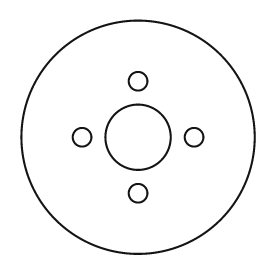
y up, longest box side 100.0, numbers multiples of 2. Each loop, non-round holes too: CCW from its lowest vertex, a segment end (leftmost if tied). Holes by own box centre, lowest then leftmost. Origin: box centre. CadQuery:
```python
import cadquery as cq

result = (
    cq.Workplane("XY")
    .moveTo(0.0, 0.0)
    .circle(50.0)
    .moveTo(0.0, -24.0)
    .circle(4.0)
    .moveTo(-24.0, 0.0)
    .circle(4.0)
    .moveTo(0.0, 0.0)
    .circle(14.0)
    .moveTo(24.0, 0.0)
    .circle(4.0)
    .moveTo(0.0, 24.0)
    .circle(4.0)
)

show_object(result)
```